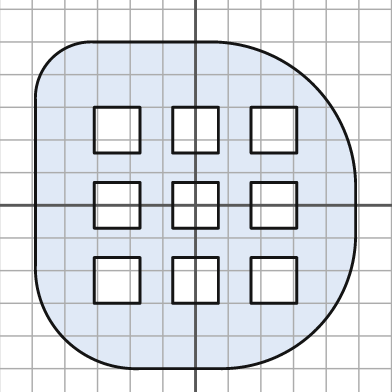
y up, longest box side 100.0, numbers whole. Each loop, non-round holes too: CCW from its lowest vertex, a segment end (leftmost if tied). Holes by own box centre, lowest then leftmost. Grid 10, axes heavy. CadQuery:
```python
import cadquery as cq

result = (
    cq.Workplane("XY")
    .moveTo(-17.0, -50.0)
    .lineTo(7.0, -50.0)
    .threePointArc((37.0, -38.0), (49.0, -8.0))
    .lineTo(49.0, 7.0)
    .threePointArc((36.0, 37.0), (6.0, 50.0))
    .lineTo(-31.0, 50.0)
    .threePointArc((-44.0, 45.0), (-49.0, 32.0))
    .lineTo(-49.0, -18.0)
    .threePointArc((-40.0, -41.0), (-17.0, -50.0))
    .close()
    .moveTo(-31.0, -30.0)
    .lineTo(-17.0, -30.0)
    .lineTo(-17.0, -16.0)
    .lineTo(-31.0, -16.0)
    .close()
    .moveTo(-7.0, -30.0)
    .lineTo(7.0, -30.0)
    .lineTo(7.0, -16.0)
    .lineTo(-7.0, -16.0)
    .close()
    .moveTo(17.0, -30.0)
    .lineTo(31.0, -30.0)
    .lineTo(31.0, -16.0)
    .lineTo(17.0, -16.0)
    .close()
    .moveTo(-31.0, -7.0)
    .lineTo(-17.0, -7.0)
    .lineTo(-17.0, 7.0)
    .lineTo(-31.0, 7.0)
    .close()
    .moveTo(-7.0, -7.0)
    .lineTo(7.0, -7.0)
    .lineTo(7.0, 7.0)
    .lineTo(-7.0, 7.0)
    .close()
    .moveTo(17.0, -7.0)
    .lineTo(31.0, -7.0)
    .lineTo(31.0, 7.0)
    .lineTo(17.0, 7.0)
    .close()
    .moveTo(-31.0, 16.0)
    .lineTo(-17.0, 16.0)
    .lineTo(-17.0, 30.0)
    .lineTo(-31.0, 30.0)
    .close()
    .moveTo(-7.0, 16.0)
    .lineTo(7.0, 16.0)
    .lineTo(7.0, 30.0)
    .lineTo(-7.0, 30.0)
    .close()
    .moveTo(17.0, 16.0)
    .lineTo(31.0, 16.0)
    .lineTo(31.0, 30.0)
    .lineTo(17.0, 30.0)
    .close()
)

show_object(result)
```